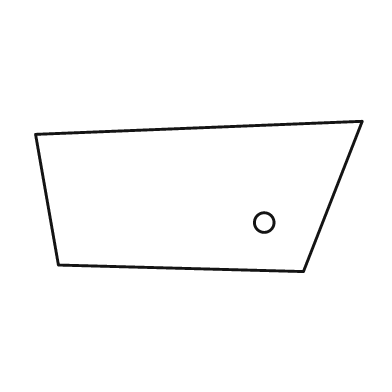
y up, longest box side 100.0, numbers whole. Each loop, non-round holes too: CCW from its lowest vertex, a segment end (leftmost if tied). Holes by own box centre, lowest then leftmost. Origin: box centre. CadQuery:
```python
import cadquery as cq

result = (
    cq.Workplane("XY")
    .moveTo(32.0, -23.0)
    .lineTo(50.0, 23.0)
    .lineTo(-50.0, 19.0)
    .lineTo(-43.0, -21.0)
    .close()
    .moveTo(20.0, -8.0)
    .circle(3.0)
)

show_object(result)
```